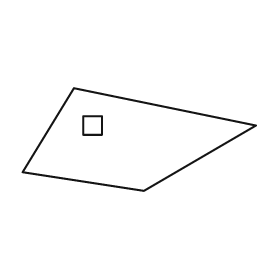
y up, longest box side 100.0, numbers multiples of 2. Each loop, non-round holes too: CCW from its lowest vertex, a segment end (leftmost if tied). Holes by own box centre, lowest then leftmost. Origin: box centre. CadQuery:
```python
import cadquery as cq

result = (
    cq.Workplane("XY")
    .moveTo(2.0, -22.0)
    .lineTo(50.0, 6.0)
    .lineTo(-28.0, 22.0)
    .lineTo(-50.0, -14.0)
    .close()
    .moveTo(-24.0, 2.0)
    .lineTo(-16.0, 2.0)
    .lineTo(-16.0, 10.0)
    .lineTo(-24.0, 10.0)
    .close()
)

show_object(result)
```